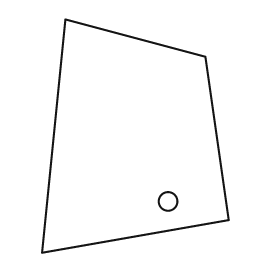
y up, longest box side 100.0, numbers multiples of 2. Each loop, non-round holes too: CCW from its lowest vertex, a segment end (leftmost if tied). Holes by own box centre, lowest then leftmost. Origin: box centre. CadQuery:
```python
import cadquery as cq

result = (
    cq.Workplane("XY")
    .moveTo(-40.0, -50.0)
    .lineTo(40.0, -36.0)
    .lineTo(30.0, 34.0)
    .lineTo(-30.0, 50.0)
    .close()
    .moveTo(14.0, -28.0)
    .circle(4.0)
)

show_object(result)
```